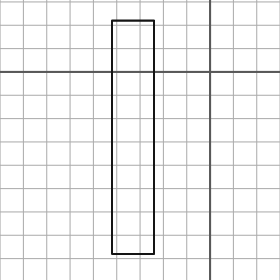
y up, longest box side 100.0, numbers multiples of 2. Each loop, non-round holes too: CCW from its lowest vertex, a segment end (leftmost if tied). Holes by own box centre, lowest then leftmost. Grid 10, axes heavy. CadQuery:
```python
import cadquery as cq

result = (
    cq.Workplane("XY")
    .moveTo(-42.0, -78.0)
    .lineTo(-24.0, -78.0)
    .lineTo(-24.0, 22.0)
    .lineTo(-42.0, 22.0)
    .close()
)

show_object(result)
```